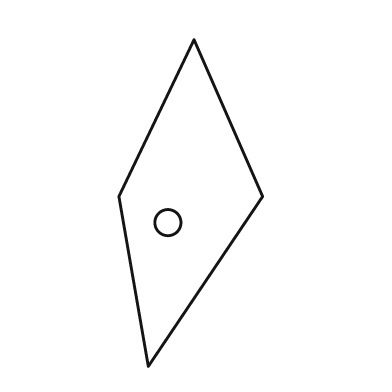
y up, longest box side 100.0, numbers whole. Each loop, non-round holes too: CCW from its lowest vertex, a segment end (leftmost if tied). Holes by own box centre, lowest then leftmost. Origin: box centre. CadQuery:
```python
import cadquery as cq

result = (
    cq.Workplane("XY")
    .moveTo(-13.0, -50.0)
    .lineTo(22.0, 2.0)
    .lineTo(1.0, 50.0)
    .lineTo(-22.0, 2.0)
    .close()
    .moveTo(-7.0, -6.0)
    .circle(4.0)
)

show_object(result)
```